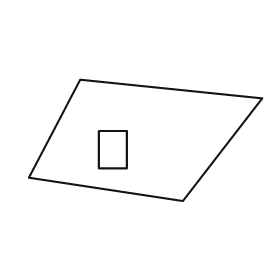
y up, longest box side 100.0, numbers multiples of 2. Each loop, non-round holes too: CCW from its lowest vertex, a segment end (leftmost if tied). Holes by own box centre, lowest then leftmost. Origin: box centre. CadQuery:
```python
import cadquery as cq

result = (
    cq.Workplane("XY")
    .moveTo(16.0, -26.0)
    .lineTo(50.0, 18.0)
    .lineTo(-28.0, 26.0)
    .lineTo(-50.0, -16.0)
    .close()
    .moveTo(-20.0, -12.0)
    .lineTo(-8.0, -12.0)
    .lineTo(-8.0, 4.0)
    .lineTo(-20.0, 4.0)
    .close()
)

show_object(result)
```